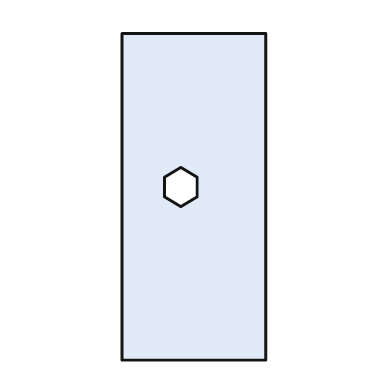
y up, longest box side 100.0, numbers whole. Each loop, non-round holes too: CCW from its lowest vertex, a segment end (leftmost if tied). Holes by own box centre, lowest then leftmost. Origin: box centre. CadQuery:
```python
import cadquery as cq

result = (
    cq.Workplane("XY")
    .moveTo(-22.0, -50.0)
    .lineTo(22.0, -50.0)
    .lineTo(22.0, 50.0)
    .lineTo(-22.0, 50.0)
    .close()
    .moveTo(-4.0, -3.0)
    .lineTo(1.0, 0.0)
    .lineTo(1.0, 6.0)
    .lineTo(-4.0, 9.0)
    .lineTo(-9.0, 6.0)
    .lineTo(-9.0, 0.0)
    .close()
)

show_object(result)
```